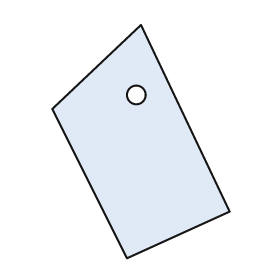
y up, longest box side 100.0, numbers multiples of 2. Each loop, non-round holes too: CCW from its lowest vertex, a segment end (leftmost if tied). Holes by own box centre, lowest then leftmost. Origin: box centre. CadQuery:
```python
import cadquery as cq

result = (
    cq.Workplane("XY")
    .moveTo(-6.0, -50.0)
    .lineTo(38.0, -30.0)
    .lineTo(0.0, 50.0)
    .lineTo(-38.0, 14.0)
    .close()
    .moveTo(-2.0, 20.0)
    .circle(4.0)
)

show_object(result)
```